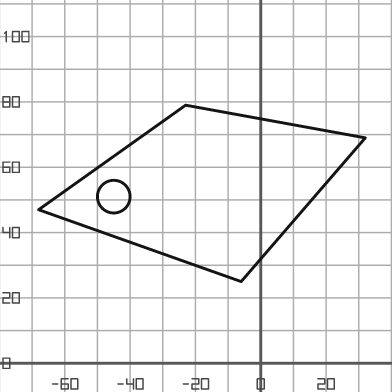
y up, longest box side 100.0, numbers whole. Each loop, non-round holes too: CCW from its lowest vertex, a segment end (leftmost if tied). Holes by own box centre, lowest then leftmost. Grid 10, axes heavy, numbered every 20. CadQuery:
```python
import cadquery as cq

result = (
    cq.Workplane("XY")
    .moveTo(-6.0, 25.0)
    .lineTo(32.0, 69.0)
    .lineTo(-23.0, 79.0)
    .lineTo(-68.0, 47.0)
    .close()
    .moveTo(-45.0, 51.0)
    .circle(5.0)
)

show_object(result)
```